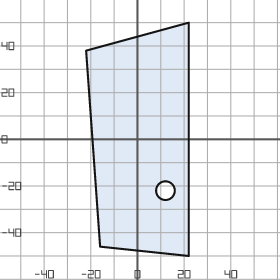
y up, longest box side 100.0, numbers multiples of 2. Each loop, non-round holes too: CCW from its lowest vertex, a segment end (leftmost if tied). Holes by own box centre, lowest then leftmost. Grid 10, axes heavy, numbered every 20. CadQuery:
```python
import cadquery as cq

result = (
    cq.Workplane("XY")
    .moveTo(22.0, -50.0)
    .lineTo(22.0, 50.0)
    .lineTo(-22.0, 38.0)
    .lineTo(-16.0, -46.0)
    .close()
    .moveTo(12.0, -22.0)
    .circle(4.0)
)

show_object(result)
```